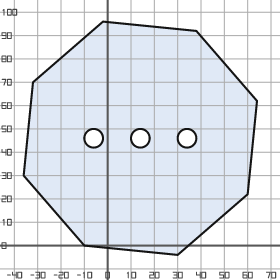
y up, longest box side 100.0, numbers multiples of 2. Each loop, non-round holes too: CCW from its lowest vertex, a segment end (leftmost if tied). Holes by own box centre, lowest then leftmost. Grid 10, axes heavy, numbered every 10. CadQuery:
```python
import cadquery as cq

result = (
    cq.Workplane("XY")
    .moveTo(30.0, -4.0)
    .lineTo(60.0, 22.0)
    .lineTo(64.0, 62.0)
    .lineTo(38.0, 92.0)
    .lineTo(-2.0, 96.0)
    .lineTo(-32.0, 70.0)
    .lineTo(-36.0, 30.0)
    .lineTo(-10.0, 0.0)
    .close()
    .moveTo(-6.0, 46.0)
    .circle(4.0)
    .moveTo(14.0, 46.0)
    .circle(4.0)
    .moveTo(34.0, 46.0)
    .circle(4.0)
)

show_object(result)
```